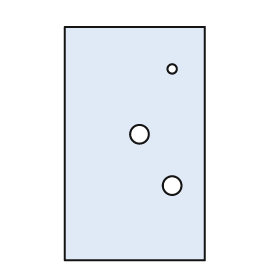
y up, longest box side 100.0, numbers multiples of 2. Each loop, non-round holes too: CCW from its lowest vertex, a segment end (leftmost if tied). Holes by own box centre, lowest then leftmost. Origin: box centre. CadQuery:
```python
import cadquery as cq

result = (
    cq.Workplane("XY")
    .moveTo(-30.0, -50.0)
    .lineTo(30.0, -50.0)
    .lineTo(30.0, 50.0)
    .lineTo(-30.0, 50.0)
    .close()
    .moveTo(16.0, -18.0)
    .circle(4.0)
    .moveTo(2.0, 4.0)
    .circle(4.0)
    .moveTo(16.0, 32.0)
    .circle(2.0)
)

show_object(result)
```